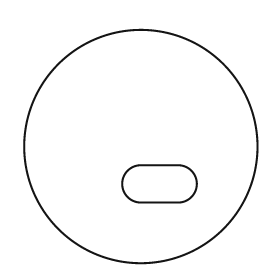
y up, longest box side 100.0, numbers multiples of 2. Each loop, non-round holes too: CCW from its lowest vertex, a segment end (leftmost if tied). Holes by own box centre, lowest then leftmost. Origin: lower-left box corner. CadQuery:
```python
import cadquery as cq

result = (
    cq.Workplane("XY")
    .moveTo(50.0, 50.0)
    .circle(50.0)
    .moveTo(50.0, 26.0)
    .lineTo(66.0, 26.0)
    .threePointArc((74.0, 34.0), (66.0, 42.0))
    .lineTo(50.0, 42.0)
    .threePointArc((42.0, 34.0), (50.0, 26.0))
    .close()
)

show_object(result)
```